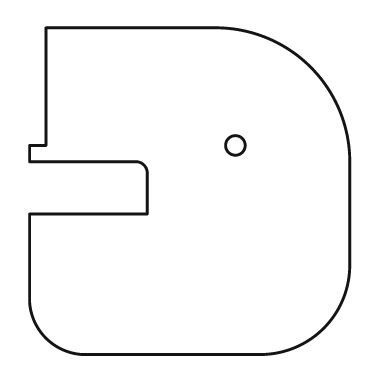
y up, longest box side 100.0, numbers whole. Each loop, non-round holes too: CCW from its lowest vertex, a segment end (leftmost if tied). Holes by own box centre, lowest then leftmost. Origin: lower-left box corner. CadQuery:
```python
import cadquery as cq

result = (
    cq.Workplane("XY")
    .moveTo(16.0, 0.0)
    .lineTo(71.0, 0.0)
    .threePointArc((90.0, 8.0), (98.0, 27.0))
    .lineTo(98.0, 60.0)
    .threePointArc((86.0, 88.0), (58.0, 100.0))
    .lineTo(5.0, 100.0)
    .lineTo(5.0, 64.0)
    .lineTo(0.0, 64.0)
    .lineTo(0.0, 59.0)
    .lineTo(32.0, 59.0)
    .threePointArc((35.0, 58.0), (36.0, 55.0))
    .lineTo(36.0, 43.0)
    .lineTo(0.0, 43.0)
    .lineTo(0.0, 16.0)
    .threePointArc((5.0, 5.0), (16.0, 0.0))
    .close()
    .moveTo(63.0, 64.0)
    .circle(3.0)
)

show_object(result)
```